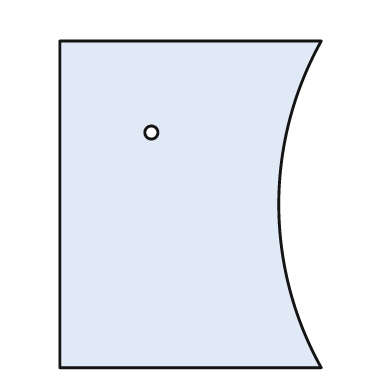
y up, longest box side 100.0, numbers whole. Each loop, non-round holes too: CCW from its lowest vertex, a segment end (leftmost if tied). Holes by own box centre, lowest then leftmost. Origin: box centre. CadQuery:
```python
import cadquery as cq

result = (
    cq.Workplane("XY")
    .moveTo(-40.0, -50.0)
    .lineTo(40.0, -50.0)
    .threePointArc((27.0, 0.0), (40.0, 50.0))
    .lineTo(-40.0, 50.0)
    .close()
    .moveTo(-12.0, 22.0)
    .circle(2.0)
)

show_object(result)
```